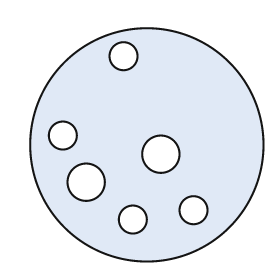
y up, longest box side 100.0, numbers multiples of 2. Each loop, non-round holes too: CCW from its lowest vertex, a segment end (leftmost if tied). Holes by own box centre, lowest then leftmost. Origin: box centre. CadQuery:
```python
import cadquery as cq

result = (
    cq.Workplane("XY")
    .moveTo(0.0, 0.0)
    .circle(50.0)
    .moveTo(-6.0, -32.0)
    .circle(6.0)
    .moveTo(20.0, -28.0)
    .circle(6.0)
    .moveTo(-26.0, -16.0)
    .circle(8.0)
    .moveTo(6.0, -4.0)
    .circle(8.0)
    .moveTo(-36.0, 4.0)
    .circle(6.0)
    .moveTo(-10.0, 38.0)
    .circle(6.0)
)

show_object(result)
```